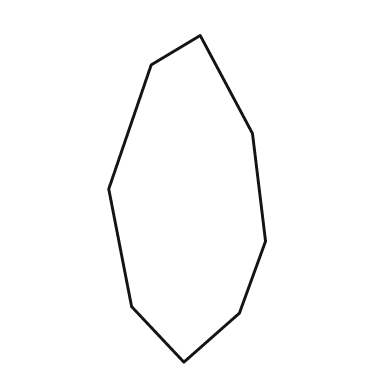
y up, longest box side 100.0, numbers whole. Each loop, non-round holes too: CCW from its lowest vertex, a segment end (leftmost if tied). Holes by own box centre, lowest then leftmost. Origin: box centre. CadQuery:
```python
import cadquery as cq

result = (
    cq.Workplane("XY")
    .moveTo(-1.0, -50.0)
    .lineTo(16.0, -35.0)
    .lineTo(24.0, -13.0)
    .lineTo(20.0, 20.0)
    .lineTo(4.0, 50.0)
    .lineTo(-11.0, 41.0)
    .lineTo(-24.0, 3.0)
    .lineTo(-17.0, -33.0)
    .close()
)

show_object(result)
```